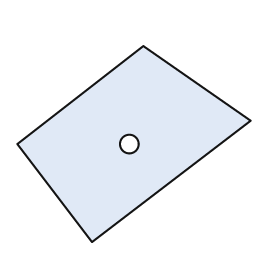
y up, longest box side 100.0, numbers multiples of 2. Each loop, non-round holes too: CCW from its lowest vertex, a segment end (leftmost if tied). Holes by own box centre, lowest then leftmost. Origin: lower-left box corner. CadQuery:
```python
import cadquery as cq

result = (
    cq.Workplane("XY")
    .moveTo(32.0, 0.0)
    .lineTo(100.0, 52.0)
    .lineTo(54.0, 84.0)
    .lineTo(0.0, 42.0)
    .close()
    .moveTo(48.0, 42.0)
    .circle(4.0)
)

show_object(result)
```